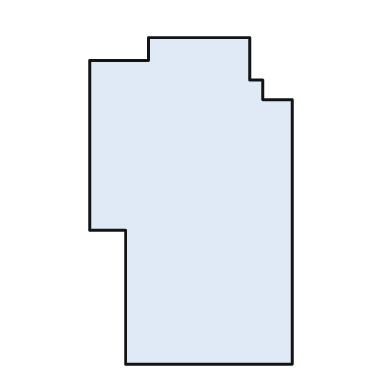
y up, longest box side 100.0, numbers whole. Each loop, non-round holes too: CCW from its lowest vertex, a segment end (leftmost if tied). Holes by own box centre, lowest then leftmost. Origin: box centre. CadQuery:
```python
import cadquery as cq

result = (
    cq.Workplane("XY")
    .moveTo(-20.0, -50.0)
    .lineTo(31.0, -50.0)
    .lineTo(31.0, 31.0)
    .lineTo(22.0, 31.0)
    .lineTo(22.0, 37.0)
    .lineTo(18.0, 37.0)
    .lineTo(18.0, 50.0)
    .lineTo(-13.0, 50.0)
    .lineTo(-13.0, 43.0)
    .lineTo(-31.0, 43.0)
    .lineTo(-31.0, -9.0)
    .lineTo(-20.0, -9.0)
    .close()
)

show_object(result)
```